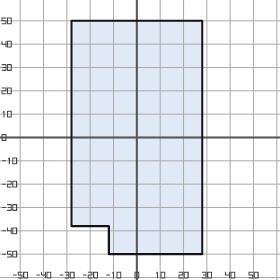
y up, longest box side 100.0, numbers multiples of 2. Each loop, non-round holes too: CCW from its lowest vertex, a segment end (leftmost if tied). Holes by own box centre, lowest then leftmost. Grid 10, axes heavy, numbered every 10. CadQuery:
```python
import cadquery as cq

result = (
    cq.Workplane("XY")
    .moveTo(-12.0, -50.0)
    .lineTo(28.0, -50.0)
    .lineTo(28.0, 50.0)
    .lineTo(-28.0, 50.0)
    .lineTo(-28.0, -38.0)
    .lineTo(-12.0, -38.0)
    .close()
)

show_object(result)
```